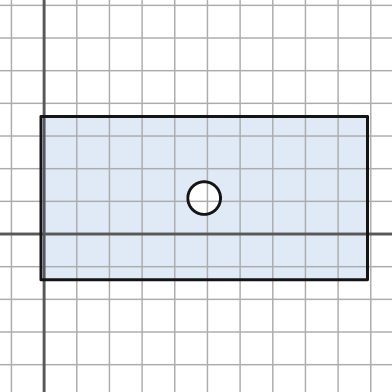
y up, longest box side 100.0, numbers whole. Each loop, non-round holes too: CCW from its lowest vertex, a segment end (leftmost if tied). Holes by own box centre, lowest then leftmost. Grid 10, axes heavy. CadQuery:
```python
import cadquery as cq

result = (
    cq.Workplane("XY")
    .moveTo(-1.0, -14.0)
    .lineTo(99.0, -14.0)
    .lineTo(99.0, 36.0)
    .lineTo(-1.0, 36.0)
    .close()
    .moveTo(49.0, 11.0)
    .circle(5.0)
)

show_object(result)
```